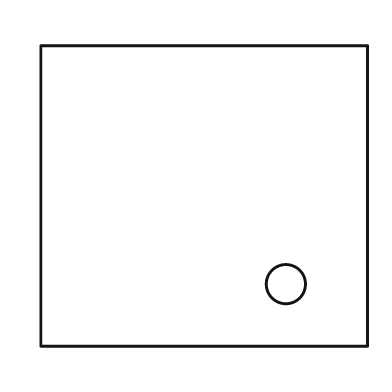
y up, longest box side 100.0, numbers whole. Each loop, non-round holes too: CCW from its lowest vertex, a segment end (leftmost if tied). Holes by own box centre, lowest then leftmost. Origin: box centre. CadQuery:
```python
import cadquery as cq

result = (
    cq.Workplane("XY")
    .moveTo(-50.0, -46.0)
    .lineTo(50.0, -46.0)
    .lineTo(50.0, 46.0)
    .lineTo(-50.0, 46.0)
    .close()
    .moveTo(25.0, -27.0)
    .circle(6.0)
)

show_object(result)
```